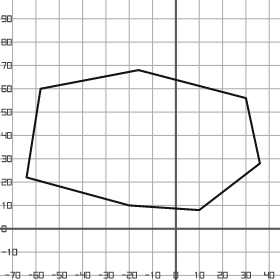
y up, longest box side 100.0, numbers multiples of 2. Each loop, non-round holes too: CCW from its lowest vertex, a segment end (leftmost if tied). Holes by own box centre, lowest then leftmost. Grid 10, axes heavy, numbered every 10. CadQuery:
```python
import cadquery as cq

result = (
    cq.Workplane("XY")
    .moveTo(10.0, 8.0)
    .lineTo(36.0, 28.0)
    .lineTo(30.0, 56.0)
    .lineTo(-16.0, 68.0)
    .lineTo(-58.0, 60.0)
    .lineTo(-64.0, 22.0)
    .lineTo(-20.0, 10.0)
    .close()
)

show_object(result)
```